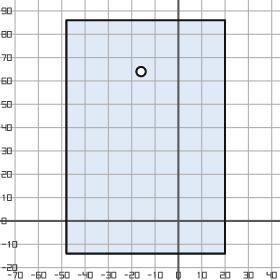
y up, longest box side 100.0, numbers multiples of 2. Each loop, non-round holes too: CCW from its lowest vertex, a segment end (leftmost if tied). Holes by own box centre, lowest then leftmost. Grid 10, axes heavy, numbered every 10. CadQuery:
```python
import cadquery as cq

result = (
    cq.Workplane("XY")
    .moveTo(-48.0, -14.0)
    .lineTo(20.0, -14.0)
    .lineTo(20.0, 86.0)
    .lineTo(-48.0, 86.0)
    .close()
    .moveTo(-16.0, 64.0)
    .circle(2.0)
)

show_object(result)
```